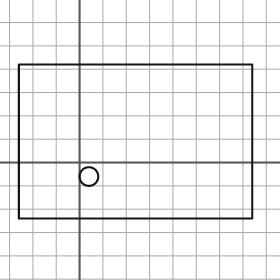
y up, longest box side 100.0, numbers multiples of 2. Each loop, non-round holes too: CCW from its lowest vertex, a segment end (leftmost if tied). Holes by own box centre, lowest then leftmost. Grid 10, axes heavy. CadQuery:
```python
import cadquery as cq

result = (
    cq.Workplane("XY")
    .moveTo(-26.0, -24.0)
    .lineTo(74.0, -24.0)
    .lineTo(74.0, 42.0)
    .lineTo(-26.0, 42.0)
    .close()
    .moveTo(4.0, -6.0)
    .circle(4.0)
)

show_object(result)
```